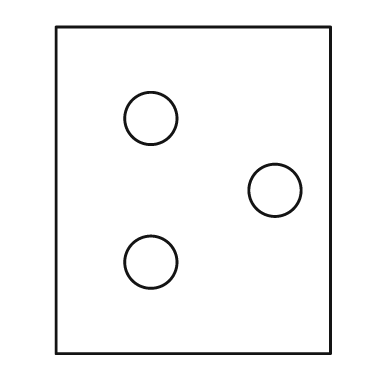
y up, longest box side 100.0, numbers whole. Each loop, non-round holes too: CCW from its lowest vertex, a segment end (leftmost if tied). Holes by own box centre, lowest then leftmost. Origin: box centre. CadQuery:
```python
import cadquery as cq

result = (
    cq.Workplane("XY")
    .moveTo(-42.0, -50.0)
    .lineTo(42.0, -50.0)
    .lineTo(42.0, 50.0)
    .lineTo(-42.0, 50.0)
    .close()
    .moveTo(-13.0, -22.0)
    .circle(8.0)
    .moveTo(25.0, 0.0)
    .circle(8.0)
    .moveTo(-13.0, 22.0)
    .circle(8.0)
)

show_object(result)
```